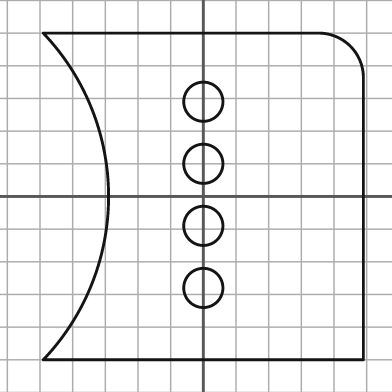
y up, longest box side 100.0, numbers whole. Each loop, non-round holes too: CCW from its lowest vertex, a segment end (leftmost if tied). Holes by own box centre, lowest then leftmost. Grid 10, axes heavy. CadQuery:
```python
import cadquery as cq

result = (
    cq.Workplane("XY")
    .moveTo(-49.0, -50.0)
    .lineTo(49.0, -50.0)
    .lineTo(49.0, 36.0)
    .threePointArc((45.0, 46.0), (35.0, 50.0))
    .lineTo(-49.0, 50.0)
    .threePointArc((-29.0, 0.0), (-49.0, -50.0))
    .close()
    .moveTo(0.0, -28.0)
    .circle(6.0)
    .moveTo(0.0, -9.0)
    .circle(6.0)
    .moveTo(0.0, 10.0)
    .circle(6.0)
    .moveTo(0.0, 29.0)
    .circle(6.0)
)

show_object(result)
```